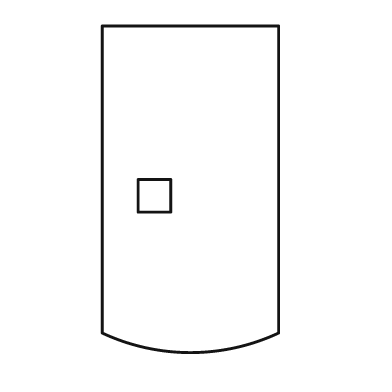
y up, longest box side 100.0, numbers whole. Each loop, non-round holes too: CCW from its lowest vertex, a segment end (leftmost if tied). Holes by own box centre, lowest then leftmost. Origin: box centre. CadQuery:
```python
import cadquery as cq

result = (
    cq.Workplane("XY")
    .moveTo(-27.0, -44.0)
    .threePointArc((0.0, -50.0), (27.0, -44.0))
    .lineTo(27.0, 50.0)
    .lineTo(-27.0, 50.0)
    .close()
    .moveTo(-16.0, -7.0)
    .lineTo(-6.0, -7.0)
    .lineTo(-6.0, 3.0)
    .lineTo(-16.0, 3.0)
    .close()
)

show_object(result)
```